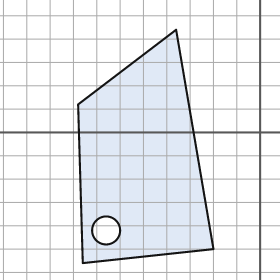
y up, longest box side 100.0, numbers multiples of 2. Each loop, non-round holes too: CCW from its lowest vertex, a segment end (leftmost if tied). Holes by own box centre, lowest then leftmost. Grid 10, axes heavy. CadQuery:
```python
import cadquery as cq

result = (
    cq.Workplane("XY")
    .moveTo(-76.0, -56.0)
    .lineTo(-20.0, -50.0)
    .lineTo(-36.0, 44.0)
    .lineTo(-78.0, 12.0)
    .close()
    .moveTo(-66.0, -42.0)
    .circle(6.0)
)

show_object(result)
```